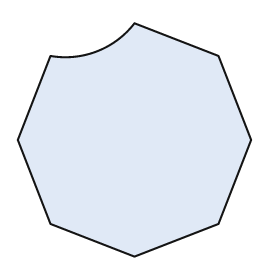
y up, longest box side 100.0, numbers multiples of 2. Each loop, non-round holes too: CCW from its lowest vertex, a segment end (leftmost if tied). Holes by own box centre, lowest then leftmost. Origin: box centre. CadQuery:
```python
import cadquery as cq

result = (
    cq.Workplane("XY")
    .moveTo(0.0, -50.0)
    .lineTo(36.0, -36.0)
    .lineTo(50.0, 0.0)
    .lineTo(36.0, 36.0)
    .lineTo(0.0, 50.0)
    .threePointArc((-16.0, 38.0), (-36.0, 36.0))
    .lineTo(-50.0, 0.0)
    .lineTo(-36.0, -36.0)
    .close()
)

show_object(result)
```